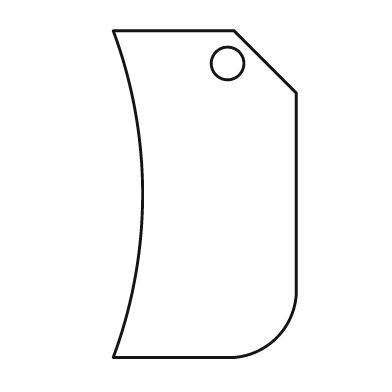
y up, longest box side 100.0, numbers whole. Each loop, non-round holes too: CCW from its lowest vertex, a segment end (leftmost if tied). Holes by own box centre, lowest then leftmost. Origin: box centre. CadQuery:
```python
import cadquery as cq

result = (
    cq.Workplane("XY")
    .moveTo(-28.0, -50.0)
    .lineTo(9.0, -50.0)
    .threePointArc((22.0, -44.0), (28.0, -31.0))
    .lineTo(28.0, 31.0)
    .lineTo(9.0, 50.0)
    .lineTo(-28.0, 50.0)
    .threePointArc((-19.0, 0.0), (-28.0, -50.0))
    .close()
    .moveTo(7.0, 40.0)
    .circle(5.0)
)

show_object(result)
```